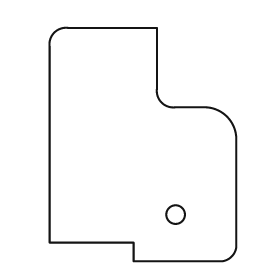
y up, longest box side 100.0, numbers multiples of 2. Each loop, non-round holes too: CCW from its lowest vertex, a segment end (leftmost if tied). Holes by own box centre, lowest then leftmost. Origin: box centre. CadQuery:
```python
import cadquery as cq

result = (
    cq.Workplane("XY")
    .moveTo(-4.0, -50.0)
    .lineTo(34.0, -50.0)
    .threePointArc((38.0, -48.0), (40.0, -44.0))
    .lineTo(40.0, 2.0)
    .threePointArc((36.0, 12.0), (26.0, 16.0))
    .lineTo(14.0, 16.0)
    .threePointArc((8.0, 18.0), (6.0, 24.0))
    .lineTo(6.0, 50.0)
    .lineTo(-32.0, 50.0)
    .threePointArc((-38.0, 48.0), (-40.0, 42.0))
    .lineTo(-40.0, -42.0)
    .lineTo(-4.0, -42.0)
    .close()
    .moveTo(14.0, -30.0)
    .circle(4.0)
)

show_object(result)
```